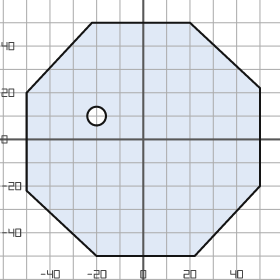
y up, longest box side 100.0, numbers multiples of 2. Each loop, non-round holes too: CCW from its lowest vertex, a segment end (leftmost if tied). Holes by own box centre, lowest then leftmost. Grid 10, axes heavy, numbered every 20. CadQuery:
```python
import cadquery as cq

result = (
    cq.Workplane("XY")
    .moveTo(-20.0, -50.0)
    .lineTo(22.0, -50.0)
    .lineTo(50.0, -20.0)
    .lineTo(50.0, 22.0)
    .lineTo(20.0, 50.0)
    .lineTo(-22.0, 50.0)
    .lineTo(-50.0, 20.0)
    .lineTo(-50.0, -22.0)
    .close()
    .moveTo(-20.0, 10.0)
    .circle(4.0)
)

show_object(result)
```